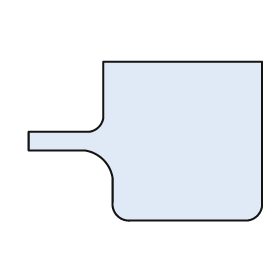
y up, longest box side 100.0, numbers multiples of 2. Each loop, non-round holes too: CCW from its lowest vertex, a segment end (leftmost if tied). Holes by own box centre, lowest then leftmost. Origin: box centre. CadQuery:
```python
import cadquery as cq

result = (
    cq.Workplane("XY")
    .moveTo(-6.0, -34.0)
    .lineTo(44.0, -34.0)
    .threePointArc((48.0, -32.0), (50.0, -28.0))
    .lineTo(50.0, 34.0)
    .lineTo(-18.0, 34.0)
    .lineTo(-18.0, 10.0)
    .threePointArc((-20.0, 6.0), (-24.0, 4.0))
    .lineTo(-50.0, 4.0)
    .lineTo(-50.0, -4.0)
    .lineTo(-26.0, -4.0)
    .threePointArc((-18.0, -8.0), (-14.0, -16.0))
    .lineTo(-14.0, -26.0)
    .threePointArc((-12.0, -32.0), (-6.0, -34.0))
    .close()
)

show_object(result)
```